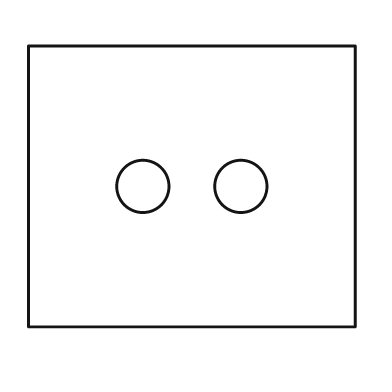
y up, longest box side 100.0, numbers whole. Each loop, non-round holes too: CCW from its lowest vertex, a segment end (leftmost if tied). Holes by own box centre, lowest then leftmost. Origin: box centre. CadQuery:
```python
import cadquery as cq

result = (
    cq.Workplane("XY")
    .moveTo(-50.0, -43.0)
    .lineTo(50.0, -43.0)
    .lineTo(50.0, 43.0)
    .lineTo(-50.0, 43.0)
    .close()
    .moveTo(-15.0, 0.0)
    .circle(8.0)
    .moveTo(15.0, 0.0)
    .circle(8.0)
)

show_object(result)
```